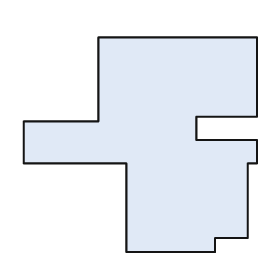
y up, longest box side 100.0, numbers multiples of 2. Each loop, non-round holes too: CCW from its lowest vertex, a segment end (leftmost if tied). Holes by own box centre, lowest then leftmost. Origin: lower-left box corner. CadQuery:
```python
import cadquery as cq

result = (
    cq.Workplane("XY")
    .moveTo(44.0, 0.0)
    .lineTo(82.0, 0.0)
    .lineTo(82.0, 6.0)
    .lineTo(96.0, 6.0)
    .lineTo(96.0, 38.0)
    .lineTo(100.0, 38.0)
    .lineTo(100.0, 48.0)
    .lineTo(74.0, 48.0)
    .lineTo(74.0, 58.0)
    .lineTo(100.0, 58.0)
    .lineTo(100.0, 92.0)
    .lineTo(32.0, 92.0)
    .lineTo(32.0, 56.0)
    .lineTo(0.0, 56.0)
    .lineTo(0.0, 38.0)
    .lineTo(44.0, 38.0)
    .close()
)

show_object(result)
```